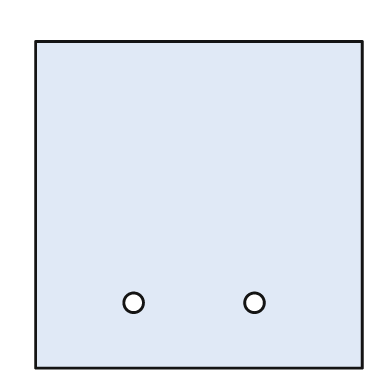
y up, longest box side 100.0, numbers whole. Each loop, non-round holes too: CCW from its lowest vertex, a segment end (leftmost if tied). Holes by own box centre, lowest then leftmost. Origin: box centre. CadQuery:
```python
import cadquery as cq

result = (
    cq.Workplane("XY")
    .moveTo(-50.0, -50.0)
    .lineTo(50.0, -50.0)
    .lineTo(50.0, 50.0)
    .lineTo(-50.0, 50.0)
    .close()
    .moveTo(-20.0, -30.0)
    .circle(3.0)
    .moveTo(17.0, -30.0)
    .circle(3.0)
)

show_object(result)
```